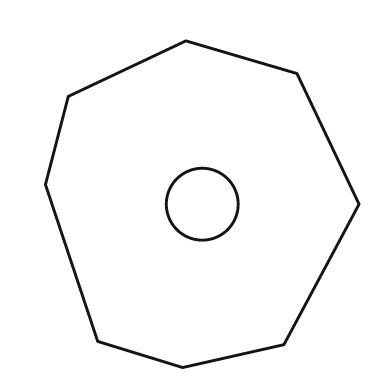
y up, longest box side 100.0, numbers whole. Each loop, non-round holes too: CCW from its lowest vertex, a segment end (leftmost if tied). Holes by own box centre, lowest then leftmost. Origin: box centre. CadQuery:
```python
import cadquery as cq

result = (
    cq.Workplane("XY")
    .moveTo(-6.0, -50.0)
    .lineTo(25.0, -43.0)
    .lineTo(48.0, 0.0)
    .lineTo(29.0, 40.0)
    .lineTo(-5.0, 50.0)
    .lineTo(-41.0, 33.0)
    .lineTo(-48.0, 6.0)
    .lineTo(-32.0, -42.0)
    .close()
    .moveTo(0.0, 0.0)
    .circle(11.0)
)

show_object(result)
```